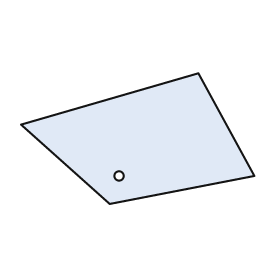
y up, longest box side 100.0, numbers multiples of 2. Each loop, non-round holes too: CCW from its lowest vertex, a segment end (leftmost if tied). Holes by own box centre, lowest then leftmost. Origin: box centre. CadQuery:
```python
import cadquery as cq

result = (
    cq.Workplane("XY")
    .moveTo(-12.0, -28.0)
    .lineTo(50.0, -16.0)
    .lineTo(26.0, 28.0)
    .lineTo(-50.0, 6.0)
    .close()
    .moveTo(-8.0, -16.0)
    .circle(2.0)
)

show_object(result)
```